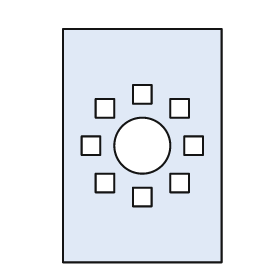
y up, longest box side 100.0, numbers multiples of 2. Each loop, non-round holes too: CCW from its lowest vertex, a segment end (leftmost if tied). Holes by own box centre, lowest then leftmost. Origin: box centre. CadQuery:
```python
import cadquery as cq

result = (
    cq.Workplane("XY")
    .moveTo(-34.0, -50.0)
    .lineTo(34.0, -50.0)
    .lineTo(34.0, 50.0)
    .lineTo(-34.0, 50.0)
    .close()
    .moveTo(-4.0, -26.0)
    .lineTo(4.0, -26.0)
    .lineTo(4.0, -18.0)
    .lineTo(-4.0, -18.0)
    .close()
    .moveTo(-20.0, -20.0)
    .lineTo(-12.0, -20.0)
    .lineTo(-12.0, -12.0)
    .lineTo(-20.0, -12.0)
    .close()
    .moveTo(12.0, -20.0)
    .lineTo(20.0, -20.0)
    .lineTo(20.0, -12.0)
    .lineTo(12.0, -12.0)
    .close()
    .moveTo(-26.0, -4.0)
    .lineTo(-18.0, -4.0)
    .lineTo(-18.0, 4.0)
    .lineTo(-26.0, 4.0)
    .close()
    .moveTo(0.0, 0.0)
    .circle(12.0)
    .moveTo(18.0, -4.0)
    .lineTo(26.0, -4.0)
    .lineTo(26.0, 4.0)
    .lineTo(18.0, 4.0)
    .close()
    .moveTo(-20.0, 12.0)
    .lineTo(-12.0, 12.0)
    .lineTo(-12.0, 20.0)
    .lineTo(-20.0, 20.0)
    .close()
    .moveTo(12.0, 12.0)
    .lineTo(20.0, 12.0)
    .lineTo(20.0, 20.0)
    .lineTo(12.0, 20.0)
    .close()
    .moveTo(-4.0, 18.0)
    .lineTo(4.0, 18.0)
    .lineTo(4.0, 26.0)
    .lineTo(-4.0, 26.0)
    .close()
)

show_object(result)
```